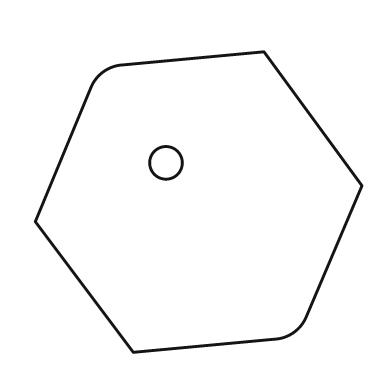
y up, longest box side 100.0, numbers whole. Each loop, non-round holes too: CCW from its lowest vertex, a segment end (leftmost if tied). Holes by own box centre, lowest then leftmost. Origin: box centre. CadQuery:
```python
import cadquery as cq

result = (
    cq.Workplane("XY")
    .moveTo(-20.0, -46.0)
    .lineTo(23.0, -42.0)
    .threePointArc((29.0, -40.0), (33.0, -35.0))
    .lineTo(50.0, 5.0)
    .lineTo(20.0, 46.0)
    .lineTo(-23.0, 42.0)
    .threePointArc((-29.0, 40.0), (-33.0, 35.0))
    .lineTo(-50.0, -6.0)
    .close()
    .moveTo(-10.0, 12.0)
    .circle(5.0)
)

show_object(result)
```